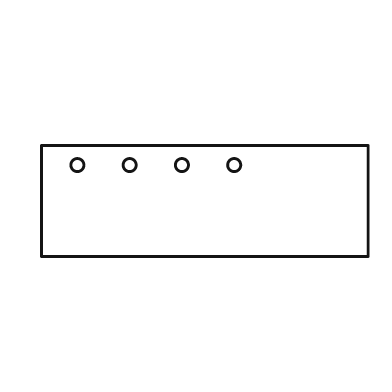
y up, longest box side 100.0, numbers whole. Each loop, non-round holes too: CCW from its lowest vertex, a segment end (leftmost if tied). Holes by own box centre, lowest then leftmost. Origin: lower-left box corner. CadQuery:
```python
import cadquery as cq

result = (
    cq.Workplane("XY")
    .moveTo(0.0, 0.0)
    .lineTo(100.0, 0.0)
    .lineTo(100.0, 34.0)
    .lineTo(0.0, 34.0)
    .close()
    .moveTo(11.0, 28.0)
    .circle(2.0)
    .moveTo(27.0, 28.0)
    .circle(2.0)
    .moveTo(43.0, 28.0)
    .circle(2.0)
    .moveTo(59.0, 28.0)
    .circle(2.0)
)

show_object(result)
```